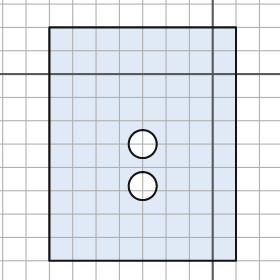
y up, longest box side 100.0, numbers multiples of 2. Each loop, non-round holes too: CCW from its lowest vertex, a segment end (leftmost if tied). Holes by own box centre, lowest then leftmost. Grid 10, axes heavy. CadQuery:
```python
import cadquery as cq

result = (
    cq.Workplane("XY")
    .moveTo(-70.0, -80.0)
    .lineTo(10.0, -80.0)
    .lineTo(10.0, 20.0)
    .lineTo(-70.0, 20.0)
    .close()
    .moveTo(-30.0, -48.0)
    .circle(6.0)
    .moveTo(-30.0, -30.0)
    .circle(6.0)
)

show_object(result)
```